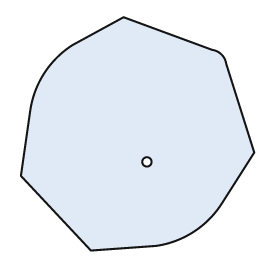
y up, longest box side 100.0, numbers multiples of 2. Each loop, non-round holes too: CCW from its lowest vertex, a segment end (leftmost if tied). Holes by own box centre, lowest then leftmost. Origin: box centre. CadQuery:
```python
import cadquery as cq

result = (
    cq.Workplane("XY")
    .moveTo(-20.0, -50.0)
    .lineTo(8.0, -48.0)
    .threePointArc((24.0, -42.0), (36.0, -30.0))
    .lineTo(50.0, -8.0)
    .lineTo(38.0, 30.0)
    .threePointArc((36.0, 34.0), (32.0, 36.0))
    .lineTo(-6.0, 50.0)
    .lineTo(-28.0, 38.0)
    .threePointArc((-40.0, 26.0), (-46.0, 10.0))
    .lineTo(-50.0, -18.0)
    .close()
    .moveTo(4.0, -12.0)
    .circle(2.0)
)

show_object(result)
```